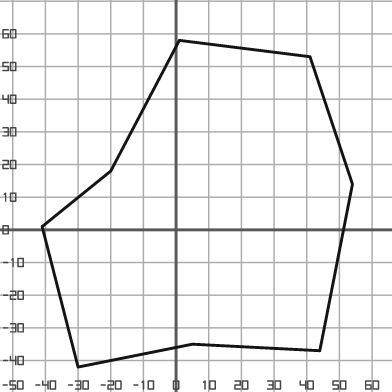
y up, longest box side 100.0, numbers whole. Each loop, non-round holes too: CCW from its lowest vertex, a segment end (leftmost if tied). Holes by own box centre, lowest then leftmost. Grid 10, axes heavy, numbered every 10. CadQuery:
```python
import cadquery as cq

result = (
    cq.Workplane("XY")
    .moveTo(-30.0, -42.0)
    .lineTo(5.0, -35.0)
    .lineTo(44.0, -37.0)
    .lineTo(54.0, 14.0)
    .lineTo(41.0, 53.0)
    .lineTo(1.0, 58.0)
    .lineTo(-20.0, 18.0)
    .lineTo(-41.0, 1.0)
    .close()
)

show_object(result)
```